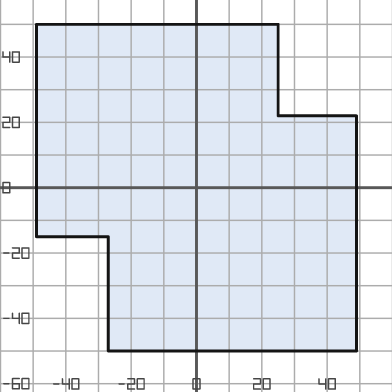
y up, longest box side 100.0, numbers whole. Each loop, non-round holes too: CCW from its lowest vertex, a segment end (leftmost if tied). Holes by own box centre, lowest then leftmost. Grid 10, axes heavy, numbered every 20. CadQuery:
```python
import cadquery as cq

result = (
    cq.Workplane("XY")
    .moveTo(-27.0, -50.0)
    .lineTo(49.0, -50.0)
    .lineTo(49.0, 22.0)
    .lineTo(25.0, 22.0)
    .lineTo(25.0, 50.0)
    .lineTo(-49.0, 50.0)
    .lineTo(-49.0, -15.0)
    .lineTo(-27.0, -15.0)
    .close()
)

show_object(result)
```